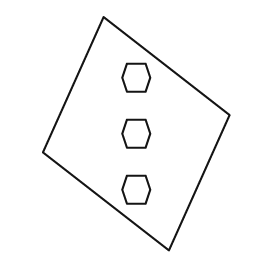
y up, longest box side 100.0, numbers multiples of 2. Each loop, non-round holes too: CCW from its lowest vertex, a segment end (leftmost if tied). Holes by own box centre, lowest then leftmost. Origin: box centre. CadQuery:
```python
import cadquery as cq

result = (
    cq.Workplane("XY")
    .moveTo(14.0, -50.0)
    .lineTo(40.0, 8.0)
    .lineTo(-14.0, 50.0)
    .lineTo(-40.0, -8.0)
    .close()
    .moveTo(-4.0, -30.0)
    .lineTo(4.0, -30.0)
    .lineTo(6.0, -24.0)
    .lineTo(4.0, -18.0)
    .lineTo(-4.0, -18.0)
    .lineTo(-6.0, -24.0)
    .close()
    .moveTo(-4.0, -6.0)
    .lineTo(4.0, -6.0)
    .lineTo(6.0, 0.0)
    .lineTo(4.0, 6.0)
    .lineTo(-4.0, 6.0)
    .lineTo(-6.0, 0.0)
    .close()
    .moveTo(-4.0, 18.0)
    .lineTo(4.0, 18.0)
    .lineTo(6.0, 24.0)
    .lineTo(4.0, 30.0)
    .lineTo(-4.0, 30.0)
    .lineTo(-6.0, 24.0)
    .close()
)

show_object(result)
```